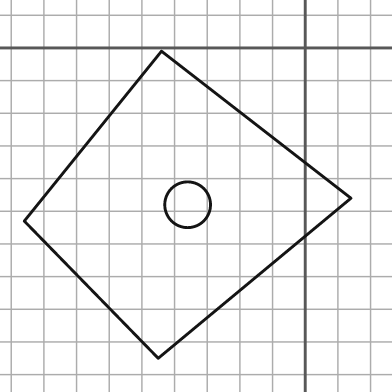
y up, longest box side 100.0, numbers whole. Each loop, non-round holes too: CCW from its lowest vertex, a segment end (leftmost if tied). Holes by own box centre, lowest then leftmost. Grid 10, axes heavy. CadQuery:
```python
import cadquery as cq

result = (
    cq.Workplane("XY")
    .moveTo(-45.0, -95.0)
    .lineTo(14.0, -46.0)
    .lineTo(-44.0, -1.0)
    .lineTo(-86.0, -53.0)
    .close()
    .moveTo(-36.0, -48.0)
    .circle(7.0)
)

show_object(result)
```